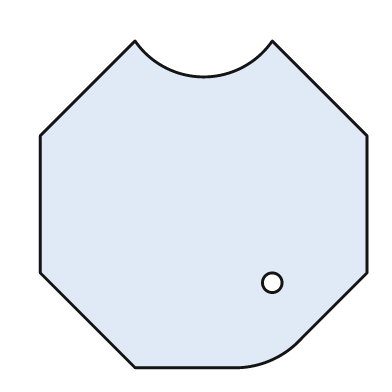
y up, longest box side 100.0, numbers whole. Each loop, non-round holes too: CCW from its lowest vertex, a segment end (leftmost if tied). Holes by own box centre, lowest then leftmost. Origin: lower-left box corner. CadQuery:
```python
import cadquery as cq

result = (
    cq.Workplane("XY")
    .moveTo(29.0, 0.0)
    .lineTo(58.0, 0.0)
    .threePointArc((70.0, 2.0), (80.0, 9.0))
    .lineTo(100.0, 29.0)
    .lineTo(100.0, 71.0)
    .lineTo(71.0, 100.0)
    .threePointArc((50.0, 89.0), (29.0, 100.0))
    .lineTo(0.0, 71.0)
    .lineTo(0.0, 29.0)
    .close()
    .moveTo(71.0, 26.0)
    .circle(3.0)
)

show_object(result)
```